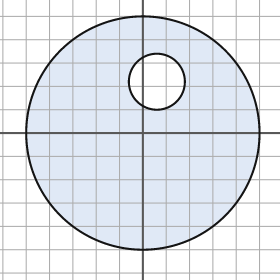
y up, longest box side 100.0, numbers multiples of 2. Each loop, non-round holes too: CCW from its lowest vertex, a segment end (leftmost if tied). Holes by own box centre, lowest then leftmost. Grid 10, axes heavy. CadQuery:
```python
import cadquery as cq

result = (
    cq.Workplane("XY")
    .moveTo(0.0, 0.0)
    .circle(50.0)
    .moveTo(6.0, 22.0)
    .circle(12.0)
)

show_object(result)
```